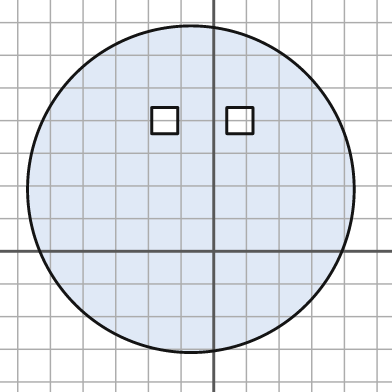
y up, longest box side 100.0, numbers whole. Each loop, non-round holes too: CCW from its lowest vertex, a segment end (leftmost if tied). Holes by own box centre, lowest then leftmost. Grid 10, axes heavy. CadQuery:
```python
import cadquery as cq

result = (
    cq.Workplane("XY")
    .moveTo(-7.0, 19.0)
    .circle(50.0)
    .moveTo(-19.0, 36.0)
    .lineTo(-11.0, 36.0)
    .lineTo(-11.0, 44.0)
    .lineTo(-19.0, 44.0)
    .close()
    .moveTo(4.0, 36.0)
    .lineTo(12.0, 36.0)
    .lineTo(12.0, 44.0)
    .lineTo(4.0, 44.0)
    .close()
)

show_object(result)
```